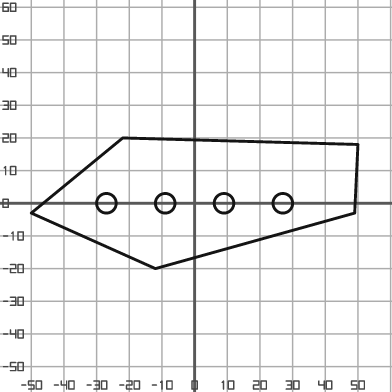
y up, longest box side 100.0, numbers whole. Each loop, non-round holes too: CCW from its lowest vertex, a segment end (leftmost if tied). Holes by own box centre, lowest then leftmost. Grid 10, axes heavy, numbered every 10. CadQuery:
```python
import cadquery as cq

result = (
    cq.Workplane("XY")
    .moveTo(-12.0, -20.0)
    .lineTo(49.0, -3.0)
    .lineTo(50.0, 18.0)
    .lineTo(-22.0, 20.0)
    .lineTo(-50.0, -3.0)
    .close()
    .moveTo(-27.0, 0.0)
    .circle(3.0)
    .moveTo(-9.0, 0.0)
    .circle(3.0)
    .moveTo(9.0, 0.0)
    .circle(3.0)
    .moveTo(27.0, 0.0)
    .circle(3.0)
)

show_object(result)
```